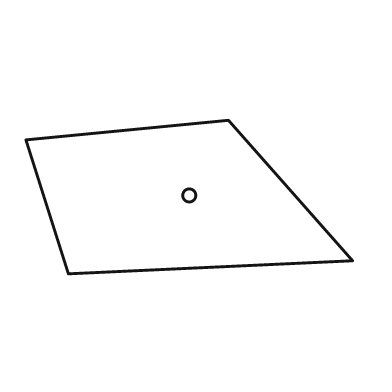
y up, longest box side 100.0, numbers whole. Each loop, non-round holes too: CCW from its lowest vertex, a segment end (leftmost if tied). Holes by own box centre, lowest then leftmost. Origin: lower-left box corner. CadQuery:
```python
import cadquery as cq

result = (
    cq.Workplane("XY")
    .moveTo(13.0, 0.0)
    .lineTo(100.0, 4.0)
    .lineTo(62.0, 47.0)
    .lineTo(0.0, 41.0)
    .close()
    .moveTo(50.0, 24.0)
    .circle(2.0)
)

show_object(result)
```